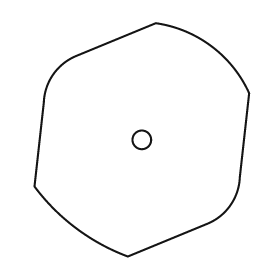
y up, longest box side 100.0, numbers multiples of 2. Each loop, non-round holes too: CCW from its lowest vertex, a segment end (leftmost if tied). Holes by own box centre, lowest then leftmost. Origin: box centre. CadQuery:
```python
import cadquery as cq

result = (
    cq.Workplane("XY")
    .moveTo(-6.0, -50.0)
    .lineTo(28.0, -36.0)
    .threePointArc((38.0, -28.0), (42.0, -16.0))
    .lineTo(46.0, 20.0)
    .threePointArc((30.0, 40.0), (6.0, 50.0))
    .lineTo(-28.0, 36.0)
    .threePointArc((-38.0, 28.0), (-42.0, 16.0))
    .lineTo(-46.0, -20.0)
    .threePointArc((-28.0, -38.0), (-6.0, -50.0))
    .close()
    .moveTo(0.0, 0.0)
    .circle(4.0)
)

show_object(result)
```